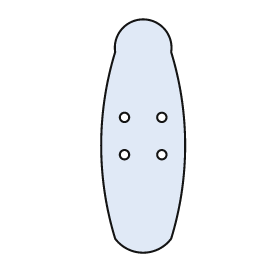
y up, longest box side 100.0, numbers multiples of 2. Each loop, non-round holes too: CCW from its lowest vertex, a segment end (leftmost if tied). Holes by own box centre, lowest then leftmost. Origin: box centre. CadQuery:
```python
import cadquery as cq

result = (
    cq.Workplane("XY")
    .moveTo(-12.0, -44.0)
    .threePointArc((0.0, -50.0), (12.0, -44.0))
    .threePointArc((18.0, -4.0), (12.0, 36.0))
    .threePointArc((0.0, 50.0), (-12.0, 36.0))
    .threePointArc((-18.0, -4.0), (-12.0, -44.0))
    .close()
    .moveTo(-8.0, -8.0)
    .circle(2.0)
    .moveTo(8.0, -8.0)
    .circle(2.0)
    .moveTo(-8.0, 8.0)
    .circle(2.0)
    .moveTo(8.0, 8.0)
    .circle(2.0)
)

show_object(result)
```